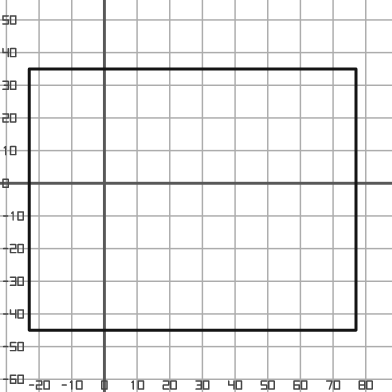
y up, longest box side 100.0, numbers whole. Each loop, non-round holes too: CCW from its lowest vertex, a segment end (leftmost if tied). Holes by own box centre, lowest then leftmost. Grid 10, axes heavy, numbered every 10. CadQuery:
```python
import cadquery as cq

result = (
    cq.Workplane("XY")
    .moveTo(-23.0, -45.0)
    .lineTo(77.0, -45.0)
    .lineTo(77.0, 35.0)
    .lineTo(-23.0, 35.0)
    .close()
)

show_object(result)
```